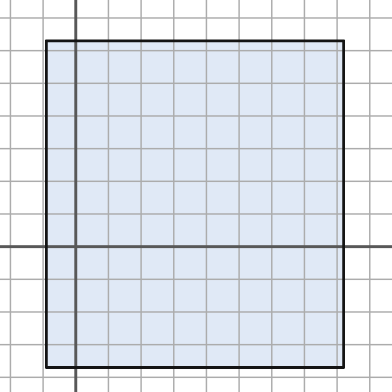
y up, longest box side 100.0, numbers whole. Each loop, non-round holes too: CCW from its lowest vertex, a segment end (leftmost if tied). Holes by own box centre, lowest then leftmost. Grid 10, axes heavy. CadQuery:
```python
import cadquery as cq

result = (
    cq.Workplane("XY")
    .moveTo(-9.0, -37.0)
    .lineTo(82.0, -37.0)
    .lineTo(82.0, 63.0)
    .lineTo(-9.0, 63.0)
    .close()
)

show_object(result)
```